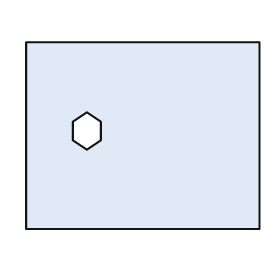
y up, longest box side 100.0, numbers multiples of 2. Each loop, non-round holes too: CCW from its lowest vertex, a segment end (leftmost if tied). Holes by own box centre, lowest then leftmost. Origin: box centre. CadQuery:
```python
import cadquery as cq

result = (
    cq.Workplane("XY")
    .moveTo(-50.0, -40.0)
    .lineTo(50.0, -40.0)
    .lineTo(50.0, 40.0)
    .lineTo(-50.0, 40.0)
    .close()
    .moveTo(-24.0, -6.0)
    .lineTo(-18.0, -2.0)
    .lineTo(-18.0, 6.0)
    .lineTo(-24.0, 10.0)
    .lineTo(-30.0, 6.0)
    .lineTo(-30.0, -2.0)
    .close()
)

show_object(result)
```